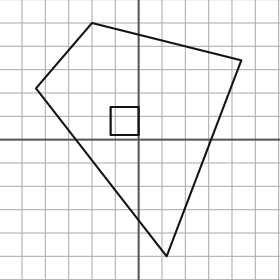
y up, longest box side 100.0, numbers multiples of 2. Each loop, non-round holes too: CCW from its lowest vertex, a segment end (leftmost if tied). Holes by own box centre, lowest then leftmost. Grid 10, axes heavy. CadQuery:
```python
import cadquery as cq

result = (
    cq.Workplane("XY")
    .moveTo(12.0, -50.0)
    .lineTo(44.0, 34.0)
    .lineTo(-20.0, 50.0)
    .lineTo(-44.0, 22.0)
    .close()
    .moveTo(-12.0, 2.0)
    .lineTo(0.0, 2.0)
    .lineTo(0.0, 14.0)
    .lineTo(-12.0, 14.0)
    .close()
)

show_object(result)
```